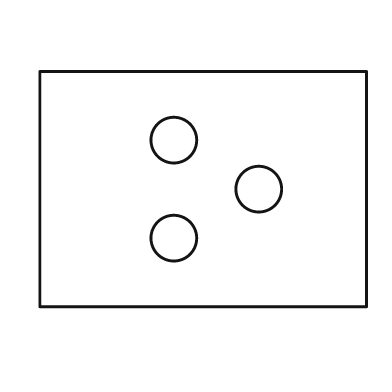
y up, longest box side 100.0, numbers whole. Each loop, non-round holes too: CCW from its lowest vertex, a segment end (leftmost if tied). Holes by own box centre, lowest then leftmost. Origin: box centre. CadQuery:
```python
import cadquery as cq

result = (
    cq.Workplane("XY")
    .moveTo(-50.0, -36.0)
    .lineTo(50.0, -36.0)
    .lineTo(50.0, 36.0)
    .lineTo(-50.0, 36.0)
    .close()
    .moveTo(-9.0, -15.0)
    .circle(7.0)
    .moveTo(17.0, 0.0)
    .circle(7.0)
    .moveTo(-9.0, 15.0)
    .circle(7.0)
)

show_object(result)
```